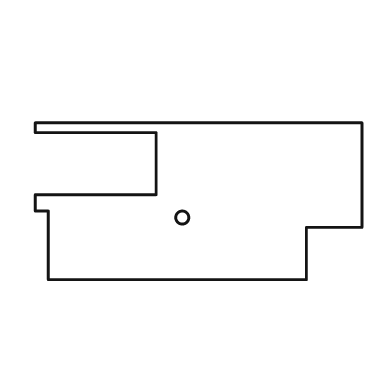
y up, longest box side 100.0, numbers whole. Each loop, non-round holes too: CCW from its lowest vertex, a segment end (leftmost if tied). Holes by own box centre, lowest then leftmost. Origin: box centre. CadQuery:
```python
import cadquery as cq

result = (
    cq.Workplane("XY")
    .moveTo(-46.0, -24.0)
    .lineTo(33.0, -24.0)
    .lineTo(33.0, -8.0)
    .lineTo(50.0, -8.0)
    .lineTo(50.0, 24.0)
    .lineTo(-50.0, 24.0)
    .lineTo(-50.0, 21.0)
    .lineTo(-13.0, 21.0)
    .lineTo(-13.0, 2.0)
    .lineTo(-50.0, 2.0)
    .lineTo(-50.0, -3.0)
    .lineTo(-46.0, -3.0)
    .close()
    .moveTo(-5.0, -5.0)
    .circle(2.0)
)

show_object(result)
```